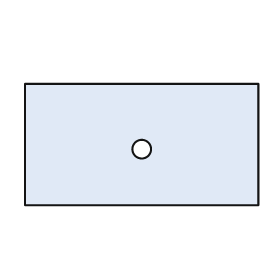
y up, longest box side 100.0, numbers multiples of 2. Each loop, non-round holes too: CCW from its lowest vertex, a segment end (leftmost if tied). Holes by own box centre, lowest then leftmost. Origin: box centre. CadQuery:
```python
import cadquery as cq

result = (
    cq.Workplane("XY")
    .moveTo(-50.0, -26.0)
    .lineTo(50.0, -26.0)
    .lineTo(50.0, 26.0)
    .lineTo(-50.0, 26.0)
    .close()
    .moveTo(0.0, -2.0)
    .circle(4.0)
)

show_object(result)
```